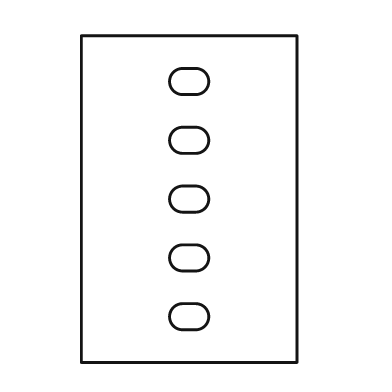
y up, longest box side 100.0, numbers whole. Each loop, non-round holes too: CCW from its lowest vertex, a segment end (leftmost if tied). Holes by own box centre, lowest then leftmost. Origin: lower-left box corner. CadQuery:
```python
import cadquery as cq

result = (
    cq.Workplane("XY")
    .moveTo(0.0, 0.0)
    .lineTo(66.0, 0.0)
    .lineTo(66.0, 100.0)
    .lineTo(0.0, 100.0)
    .close()
    .moveTo(31.0, 10.0)
    .lineTo(35.0, 10.0)
    .threePointArc((39.0, 14.0), (35.0, 18.0))
    .lineTo(31.0, 18.0)
    .threePointArc((27.0, 14.0), (31.0, 10.0))
    .close()
    .moveTo(31.0, 28.0)
    .lineTo(35.0, 28.0)
    .threePointArc((39.0, 32.0), (35.0, 36.0))
    .lineTo(31.0, 36.0)
    .threePointArc((27.0, 32.0), (31.0, 28.0))
    .close()
    .moveTo(31.0, 46.0)
    .lineTo(35.0, 46.0)
    .threePointArc((39.0, 50.0), (35.0, 54.0))
    .lineTo(31.0, 54.0)
    .threePointArc((27.0, 50.0), (31.0, 46.0))
    .close()
    .moveTo(31.0, 64.0)
    .lineTo(35.0, 64.0)
    .threePointArc((39.0, 68.0), (35.0, 72.0))
    .lineTo(31.0, 72.0)
    .threePointArc((27.0, 68.0), (31.0, 64.0))
    .close()
    .moveTo(31.0, 82.0)
    .lineTo(35.0, 82.0)
    .threePointArc((39.0, 86.0), (35.0, 90.0))
    .lineTo(31.0, 90.0)
    .threePointArc((27.0, 86.0), (31.0, 82.0))
    .close()
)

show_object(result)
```